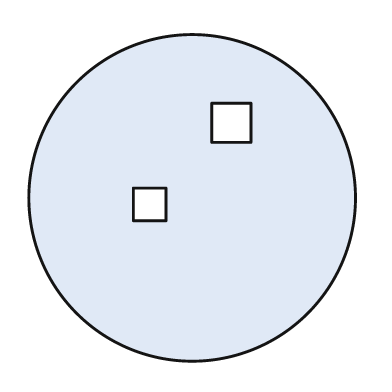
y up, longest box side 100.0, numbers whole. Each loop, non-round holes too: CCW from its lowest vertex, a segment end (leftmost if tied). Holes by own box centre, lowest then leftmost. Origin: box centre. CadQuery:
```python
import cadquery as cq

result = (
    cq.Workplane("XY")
    .moveTo(0.0, 0.0)
    .circle(50.0)
    .moveTo(-18.0, -7.0)
    .lineTo(-8.0, -7.0)
    .lineTo(-8.0, 3.0)
    .lineTo(-18.0, 3.0)
    .close()
    .moveTo(6.0, 17.0)
    .lineTo(18.0, 17.0)
    .lineTo(18.0, 29.0)
    .lineTo(6.0, 29.0)
    .close()
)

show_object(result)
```